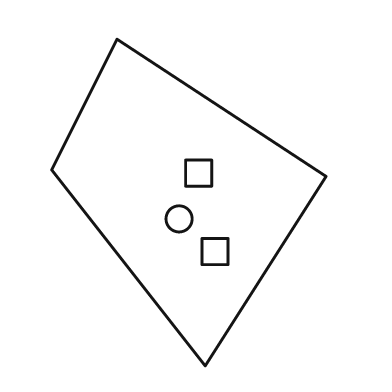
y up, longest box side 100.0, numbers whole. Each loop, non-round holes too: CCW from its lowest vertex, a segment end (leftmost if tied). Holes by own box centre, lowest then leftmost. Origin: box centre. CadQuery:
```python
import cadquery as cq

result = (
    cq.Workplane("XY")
    .moveTo(5.0, -50.0)
    .lineTo(42.0, 8.0)
    .lineTo(-22.0, 50.0)
    .lineTo(-42.0, 10.0)
    .close()
    .moveTo(4.0, -19.0)
    .lineTo(12.0, -19.0)
    .lineTo(12.0, -11.0)
    .lineTo(4.0, -11.0)
    .close()
    .moveTo(-3.0, -5.0)
    .circle(4.0)
    .moveTo(-1.0, 5.0)
    .lineTo(7.0, 5.0)
    .lineTo(7.0, 13.0)
    .lineTo(-1.0, 13.0)
    .close()
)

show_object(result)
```